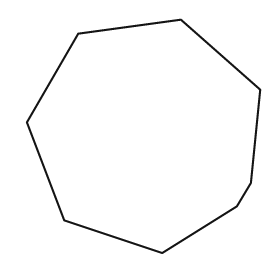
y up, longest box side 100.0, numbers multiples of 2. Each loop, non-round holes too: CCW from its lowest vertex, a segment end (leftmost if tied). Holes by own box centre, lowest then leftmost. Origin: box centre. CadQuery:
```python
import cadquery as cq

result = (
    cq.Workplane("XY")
    .moveTo(8.0, -50.0)
    .lineTo(40.0, -30.0)
    .lineTo(46.0, -20.0)
    .lineTo(50.0, 20.0)
    .lineTo(16.0, 50.0)
    .lineTo(-28.0, 44.0)
    .lineTo(-50.0, 6.0)
    .lineTo(-34.0, -36.0)
    .close()
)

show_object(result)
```